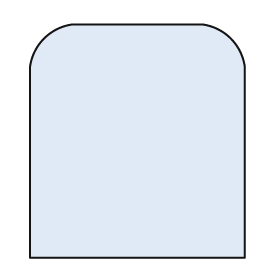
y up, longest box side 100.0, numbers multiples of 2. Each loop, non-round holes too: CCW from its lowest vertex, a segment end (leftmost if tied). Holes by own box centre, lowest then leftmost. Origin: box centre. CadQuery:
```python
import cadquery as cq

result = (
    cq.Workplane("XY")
    .moveTo(-46.0, -50.0)
    .lineTo(46.0, -50.0)
    .lineTo(46.0, 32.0)
    .threePointArc((40.0, 44.0), (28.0, 50.0))
    .lineTo(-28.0, 50.0)
    .threePointArc((-40.0, 44.0), (-46.0, 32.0))
    .close()
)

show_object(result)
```